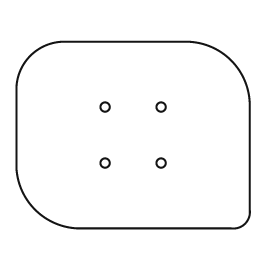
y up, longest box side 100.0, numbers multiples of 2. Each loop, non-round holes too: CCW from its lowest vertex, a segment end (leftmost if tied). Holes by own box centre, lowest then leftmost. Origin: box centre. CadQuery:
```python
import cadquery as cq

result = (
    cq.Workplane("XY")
    .moveTo(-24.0, -40.0)
    .lineTo(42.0, -40.0)
    .threePointArc((48.0, -38.0), (50.0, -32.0))
    .lineTo(50.0, 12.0)
    .threePointArc((42.0, 32.0), (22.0, 40.0))
    .lineTo(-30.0, 40.0)
    .threePointArc((-44.0, 34.0), (-50.0, 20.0))
    .lineTo(-50.0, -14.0)
    .threePointArc((-42.0, -32.0), (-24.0, -40.0))
    .close()
    .moveTo(-12.0, -12.0)
    .circle(2.0)
    .moveTo(12.0, -12.0)
    .circle(2.0)
    .moveTo(-12.0, 12.0)
    .circle(2.0)
    .moveTo(12.0, 12.0)
    .circle(2.0)
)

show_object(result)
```